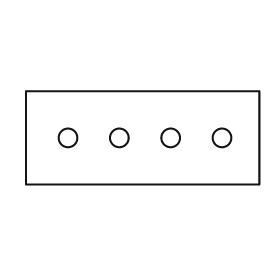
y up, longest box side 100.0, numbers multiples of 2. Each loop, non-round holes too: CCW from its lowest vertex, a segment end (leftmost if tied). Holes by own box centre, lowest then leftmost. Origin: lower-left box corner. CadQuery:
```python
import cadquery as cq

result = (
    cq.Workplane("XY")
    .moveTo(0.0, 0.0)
    .lineTo(100.0, 0.0)
    .lineTo(100.0, 40.0)
    .lineTo(0.0, 40.0)
    .close()
    .moveTo(18.0, 20.0)
    .circle(4.0)
    .moveTo(40.0, 20.0)
    .circle(4.0)
    .moveTo(62.0, 20.0)
    .circle(4.0)
    .moveTo(84.0, 20.0)
    .circle(4.0)
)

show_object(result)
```